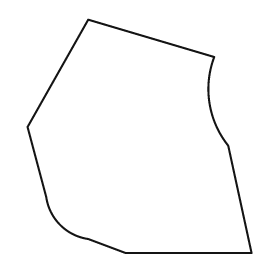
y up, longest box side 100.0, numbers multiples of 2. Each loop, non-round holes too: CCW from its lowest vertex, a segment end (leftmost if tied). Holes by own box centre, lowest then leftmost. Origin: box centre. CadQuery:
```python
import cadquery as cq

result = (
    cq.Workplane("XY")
    .moveTo(-6.0, -50.0)
    .lineTo(48.0, -50.0)
    .lineTo(38.0, -4.0)
    .threePointArc((30.0, 14.0), (32.0, 34.0))
    .lineTo(-22.0, 50.0)
    .lineTo(-48.0, 4.0)
    .lineTo(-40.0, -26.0)
    .threePointArc((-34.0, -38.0), (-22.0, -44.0))
    .close()
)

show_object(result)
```